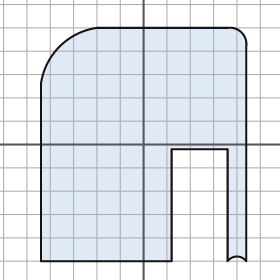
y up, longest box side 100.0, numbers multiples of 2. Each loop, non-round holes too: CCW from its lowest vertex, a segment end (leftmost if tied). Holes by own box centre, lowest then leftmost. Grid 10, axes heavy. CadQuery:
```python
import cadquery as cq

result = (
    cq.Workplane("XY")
    .moveTo(-44.0, -50.0)
    .lineTo(12.0, -50.0)
    .lineTo(12.0, -2.0)
    .lineTo(36.0, -2.0)
    .lineTo(36.0, -50.0)
    .threePointArc((40.0, -48.0), (44.0, -50.0))
    .lineTo(44.0, 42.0)
    .threePointArc((42.0, 48.0), (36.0, 50.0))
    .lineTo(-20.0, 50.0)
    .threePointArc((-36.0, 42.0), (-44.0, 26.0))
    .close()
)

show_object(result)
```